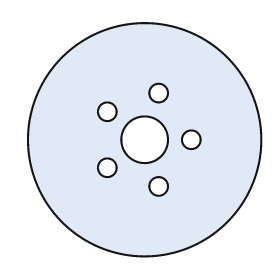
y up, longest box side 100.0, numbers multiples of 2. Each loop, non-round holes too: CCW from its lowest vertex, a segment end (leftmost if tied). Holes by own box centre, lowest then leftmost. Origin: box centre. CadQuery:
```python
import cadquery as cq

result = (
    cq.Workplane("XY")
    .moveTo(0.0, 0.0)
    .circle(50.0)
    .moveTo(6.0, -20.0)
    .circle(4.0)
    .moveTo(-16.0, -12.0)
    .circle(4.0)
    .moveTo(0.0, 0.0)
    .circle(10.0)
    .moveTo(20.0, 0.0)
    .circle(4.0)
    .moveTo(-16.0, 12.0)
    .circle(4.0)
    .moveTo(6.0, 20.0)
    .circle(4.0)
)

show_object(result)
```